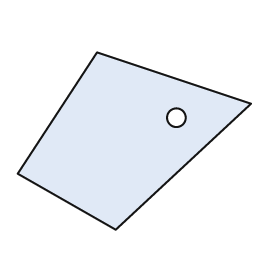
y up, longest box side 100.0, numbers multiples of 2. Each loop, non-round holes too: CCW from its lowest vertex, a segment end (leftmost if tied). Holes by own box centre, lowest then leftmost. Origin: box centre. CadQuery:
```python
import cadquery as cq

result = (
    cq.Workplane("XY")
    .moveTo(-8.0, -38.0)
    .lineTo(50.0, 16.0)
    .lineTo(-16.0, 38.0)
    .lineTo(-50.0, -14.0)
    .close()
    .moveTo(18.0, 10.0)
    .circle(4.0)
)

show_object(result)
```